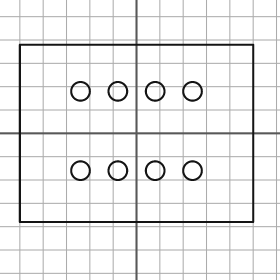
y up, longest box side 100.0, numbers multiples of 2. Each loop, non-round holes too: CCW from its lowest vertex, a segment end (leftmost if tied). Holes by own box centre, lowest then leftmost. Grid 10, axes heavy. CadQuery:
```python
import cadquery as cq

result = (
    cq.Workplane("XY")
    .moveTo(-50.0, -38.0)
    .lineTo(50.0, -38.0)
    .lineTo(50.0, 38.0)
    .lineTo(-50.0, 38.0)
    .close()
    .moveTo(-24.0, -16.0)
    .circle(4.0)
    .moveTo(-8.0, -16.0)
    .circle(4.0)
    .moveTo(8.0, -16.0)
    .circle(4.0)
    .moveTo(24.0, -16.0)
    .circle(4.0)
    .moveTo(-24.0, 18.0)
    .circle(4.0)
    .moveTo(-8.0, 18.0)
    .circle(4.0)
    .moveTo(8.0, 18.0)
    .circle(4.0)
    .moveTo(24.0, 18.0)
    .circle(4.0)
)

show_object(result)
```